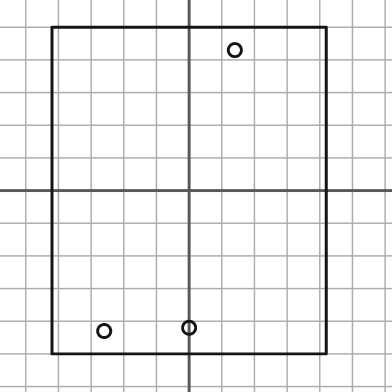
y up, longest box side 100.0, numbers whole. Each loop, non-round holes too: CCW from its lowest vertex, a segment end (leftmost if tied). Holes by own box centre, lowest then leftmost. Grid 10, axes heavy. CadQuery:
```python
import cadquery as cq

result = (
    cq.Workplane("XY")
    .moveTo(-42.0, -50.0)
    .lineTo(42.0, -50.0)
    .lineTo(42.0, 50.0)
    .lineTo(-42.0, 50.0)
    .close()
    .moveTo(-26.0, -43.0)
    .circle(2.0)
    .moveTo(0.0, -42.0)
    .circle(2.0)
    .moveTo(14.0, 43.0)
    .circle(2.0)
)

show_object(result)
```